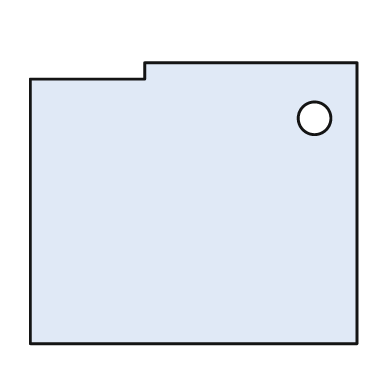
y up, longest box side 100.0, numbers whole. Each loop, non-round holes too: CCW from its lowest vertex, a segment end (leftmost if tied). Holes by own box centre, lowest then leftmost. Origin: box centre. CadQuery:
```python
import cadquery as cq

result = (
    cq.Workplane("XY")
    .moveTo(-50.0, -43.0)
    .lineTo(50.0, -43.0)
    .lineTo(50.0, 43.0)
    .lineTo(-15.0, 43.0)
    .lineTo(-15.0, 38.0)
    .lineTo(-50.0, 38.0)
    .close()
    .moveTo(37.0, 26.0)
    .circle(5.0)
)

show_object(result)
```